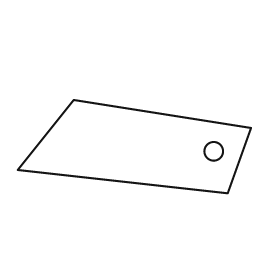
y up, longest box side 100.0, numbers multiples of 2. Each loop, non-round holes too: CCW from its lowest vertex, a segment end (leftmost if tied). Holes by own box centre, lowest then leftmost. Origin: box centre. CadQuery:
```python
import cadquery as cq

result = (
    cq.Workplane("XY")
    .moveTo(40.0, -20.0)
    .lineTo(50.0, 8.0)
    .lineTo(-26.0, 20.0)
    .lineTo(-50.0, -10.0)
    .close()
    .moveTo(34.0, -2.0)
    .circle(4.0)
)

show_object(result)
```